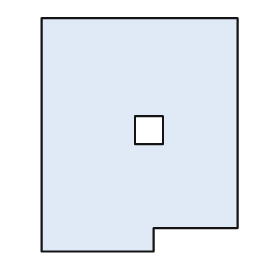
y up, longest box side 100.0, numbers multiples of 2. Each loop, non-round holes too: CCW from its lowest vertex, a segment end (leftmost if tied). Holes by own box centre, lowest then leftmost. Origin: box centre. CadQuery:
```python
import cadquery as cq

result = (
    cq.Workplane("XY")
    .moveTo(-42.0, -50.0)
    .lineTo(6.0, -50.0)
    .lineTo(6.0, -40.0)
    .lineTo(42.0, -40.0)
    .lineTo(42.0, 50.0)
    .lineTo(-42.0, 50.0)
    .close()
    .moveTo(-2.0, -4.0)
    .lineTo(10.0, -4.0)
    .lineTo(10.0, 8.0)
    .lineTo(-2.0, 8.0)
    .close()
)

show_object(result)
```